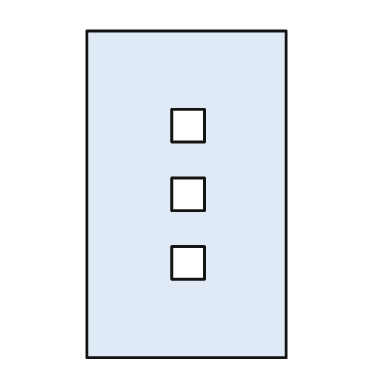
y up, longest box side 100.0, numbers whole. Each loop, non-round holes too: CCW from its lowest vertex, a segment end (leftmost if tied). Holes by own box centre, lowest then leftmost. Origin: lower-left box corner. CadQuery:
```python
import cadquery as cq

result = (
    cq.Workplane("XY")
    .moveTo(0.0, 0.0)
    .lineTo(61.0, 0.0)
    .lineTo(61.0, 100.0)
    .lineTo(0.0, 100.0)
    .close()
    .moveTo(26.0, 24.0)
    .lineTo(36.0, 24.0)
    .lineTo(36.0, 34.0)
    .lineTo(26.0, 34.0)
    .close()
    .moveTo(26.0, 45.0)
    .lineTo(36.0, 45.0)
    .lineTo(36.0, 55.0)
    .lineTo(26.0, 55.0)
    .close()
    .moveTo(26.0, 66.0)
    .lineTo(36.0, 66.0)
    .lineTo(36.0, 76.0)
    .lineTo(26.0, 76.0)
    .close()
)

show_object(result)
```